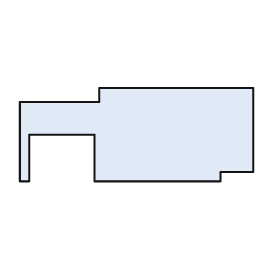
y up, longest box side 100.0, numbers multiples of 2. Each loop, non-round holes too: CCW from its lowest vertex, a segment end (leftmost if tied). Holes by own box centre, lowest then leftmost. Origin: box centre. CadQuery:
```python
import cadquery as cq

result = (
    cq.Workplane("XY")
    .moveTo(-50.0, -20.0)
    .lineTo(-46.0, -20.0)
    .lineTo(-46.0, 0.0)
    .lineTo(-18.0, 0.0)
    .lineTo(-18.0, -20.0)
    .lineTo(36.0, -20.0)
    .lineTo(36.0, -16.0)
    .lineTo(50.0, -16.0)
    .lineTo(50.0, 20.0)
    .lineTo(-16.0, 20.0)
    .lineTo(-16.0, 14.0)
    .lineTo(-50.0, 14.0)
    .close()
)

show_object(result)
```